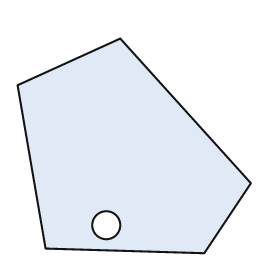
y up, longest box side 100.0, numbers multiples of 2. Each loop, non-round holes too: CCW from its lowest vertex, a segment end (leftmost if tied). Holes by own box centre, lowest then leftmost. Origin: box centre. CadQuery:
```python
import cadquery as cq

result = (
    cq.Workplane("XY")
    .moveTo(30.0, -46.0)
    .lineTo(50.0, -16.0)
    .lineTo(-6.0, 46.0)
    .lineTo(-50.0, 26.0)
    .lineTo(-38.0, -44.0)
    .close()
    .moveTo(-12.0, -34.0)
    .circle(6.0)
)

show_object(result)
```